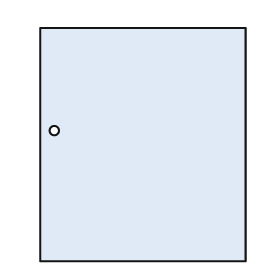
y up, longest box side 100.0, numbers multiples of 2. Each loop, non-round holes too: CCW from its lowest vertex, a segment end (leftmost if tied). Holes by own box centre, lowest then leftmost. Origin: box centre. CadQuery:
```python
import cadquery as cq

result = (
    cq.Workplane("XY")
    .moveTo(-44.0, -50.0)
    .lineTo(44.0, -50.0)
    .lineTo(44.0, 50.0)
    .lineTo(-44.0, 50.0)
    .close()
    .moveTo(-38.0, 6.0)
    .circle(2.0)
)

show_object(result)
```